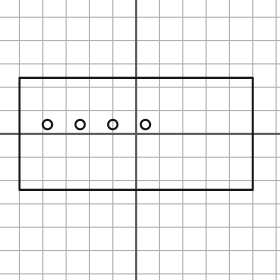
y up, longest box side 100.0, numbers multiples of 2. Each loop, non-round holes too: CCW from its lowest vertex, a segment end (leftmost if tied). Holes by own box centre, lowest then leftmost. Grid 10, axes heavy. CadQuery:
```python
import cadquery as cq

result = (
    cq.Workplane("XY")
    .moveTo(-50.0, -24.0)
    .lineTo(50.0, -24.0)
    .lineTo(50.0, 24.0)
    .lineTo(-50.0, 24.0)
    .close()
    .moveTo(-38.0, 4.0)
    .circle(2.0)
    .moveTo(-24.0, 4.0)
    .circle(2.0)
    .moveTo(-10.0, 4.0)
    .circle(2.0)
    .moveTo(4.0, 4.0)
    .circle(2.0)
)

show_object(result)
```